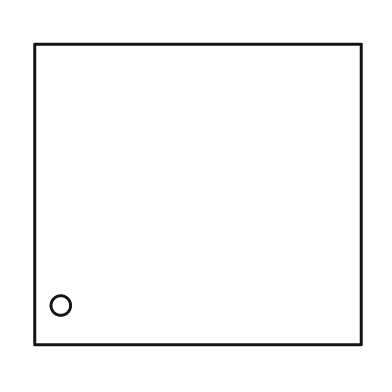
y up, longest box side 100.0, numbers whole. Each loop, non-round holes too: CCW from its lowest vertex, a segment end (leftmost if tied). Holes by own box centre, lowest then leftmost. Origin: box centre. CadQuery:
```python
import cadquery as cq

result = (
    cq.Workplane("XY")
    .moveTo(-50.0, -46.0)
    .lineTo(50.0, -46.0)
    .lineTo(50.0, 46.0)
    .lineTo(-50.0, 46.0)
    .close()
    .moveTo(-42.0, -34.0)
    .circle(3.0)
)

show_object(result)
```